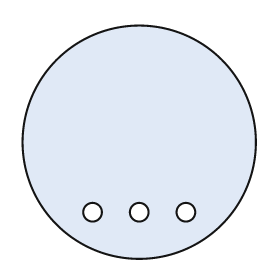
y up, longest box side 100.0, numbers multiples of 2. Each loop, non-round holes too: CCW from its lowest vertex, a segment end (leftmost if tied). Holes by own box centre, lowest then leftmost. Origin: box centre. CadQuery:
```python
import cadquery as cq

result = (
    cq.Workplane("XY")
    .moveTo(0.0, 0.0)
    .circle(50.0)
    .moveTo(-20.0, -30.0)
    .circle(4.0)
    .moveTo(0.0, -30.0)
    .circle(4.0)
    .moveTo(20.0, -30.0)
    .circle(4.0)
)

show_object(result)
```